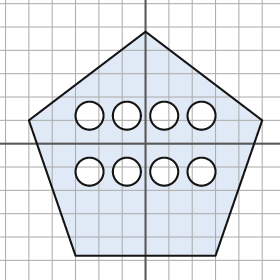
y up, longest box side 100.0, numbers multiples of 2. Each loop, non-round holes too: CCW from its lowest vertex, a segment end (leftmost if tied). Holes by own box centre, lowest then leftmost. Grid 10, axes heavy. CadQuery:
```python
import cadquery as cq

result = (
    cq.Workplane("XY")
    .moveTo(-30.0, -48.0)
    .lineTo(30.0, -48.0)
    .lineTo(50.0, 10.0)
    .lineTo(0.0, 48.0)
    .lineTo(-50.0, 10.0)
    .close()
    .moveTo(-24.0, -12.0)
    .circle(6.0)
    .moveTo(-8.0, -12.0)
    .circle(6.0)
    .moveTo(8.0, -12.0)
    .circle(6.0)
    .moveTo(24.0, -12.0)
    .circle(6.0)
    .moveTo(-24.0, 12.0)
    .circle(6.0)
    .moveTo(-8.0, 12.0)
    .circle(6.0)
    .moveTo(8.0, 12.0)
    .circle(6.0)
    .moveTo(24.0, 12.0)
    .circle(6.0)
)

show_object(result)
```